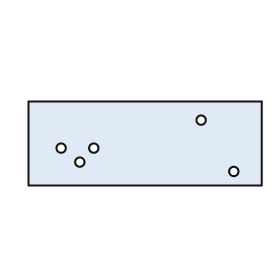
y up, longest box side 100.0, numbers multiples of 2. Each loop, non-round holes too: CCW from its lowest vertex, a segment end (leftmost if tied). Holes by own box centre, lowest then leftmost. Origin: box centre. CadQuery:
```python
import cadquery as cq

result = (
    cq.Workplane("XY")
    .moveTo(-50.0, -18.0)
    .lineTo(50.0, -18.0)
    .lineTo(50.0, 18.0)
    .lineTo(-50.0, 18.0)
    .close()
    .moveTo(38.0, -12.0)
    .circle(2.0)
    .moveTo(-28.0, -8.0)
    .circle(2.0)
    .moveTo(-36.0, -2.0)
    .circle(2.0)
    .moveTo(-22.0, -2.0)
    .circle(2.0)
    .moveTo(24.0, 10.0)
    .circle(2.0)
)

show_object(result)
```